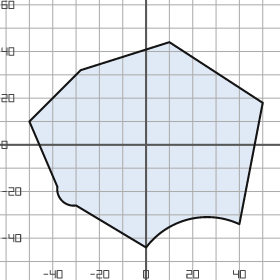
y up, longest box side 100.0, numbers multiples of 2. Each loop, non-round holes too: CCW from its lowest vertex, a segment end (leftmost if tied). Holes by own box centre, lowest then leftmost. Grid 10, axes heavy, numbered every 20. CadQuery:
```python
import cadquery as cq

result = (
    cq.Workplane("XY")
    .moveTo(0.0, -44.0)
    .threePointArc((18.0, -32.0), (40.0, -34.0))
    .lineTo(50.0, 18.0)
    .lineTo(10.0, 44.0)
    .lineTo(-28.0, 32.0)
    .lineTo(-50.0, 10.0)
    .lineTo(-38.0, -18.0)
    .threePointArc((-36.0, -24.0), (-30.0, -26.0))
    .close()
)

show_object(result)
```